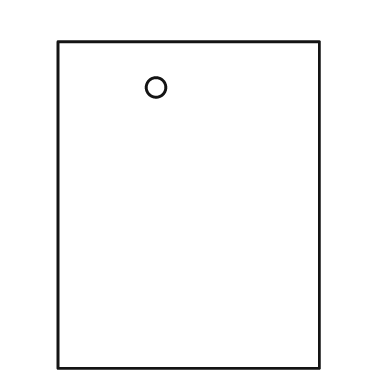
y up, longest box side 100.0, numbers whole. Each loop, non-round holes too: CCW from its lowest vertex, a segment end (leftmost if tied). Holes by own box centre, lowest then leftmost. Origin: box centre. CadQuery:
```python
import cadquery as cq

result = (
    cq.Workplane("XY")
    .moveTo(-40.0, -50.0)
    .lineTo(40.0, -50.0)
    .lineTo(40.0, 50.0)
    .lineTo(-40.0, 50.0)
    .close()
    .moveTo(-10.0, 36.0)
    .circle(3.0)
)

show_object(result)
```